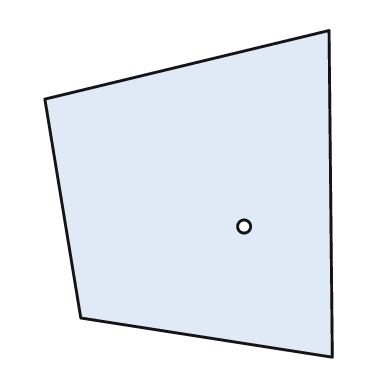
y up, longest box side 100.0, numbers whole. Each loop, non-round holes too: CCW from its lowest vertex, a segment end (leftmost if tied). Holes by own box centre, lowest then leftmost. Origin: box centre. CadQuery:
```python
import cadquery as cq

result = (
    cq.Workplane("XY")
    .moveTo(44.0, -50.0)
    .lineTo(43.0, 50.0)
    .lineTo(-44.0, 29.0)
    .lineTo(-33.0, -38.0)
    .close()
    .moveTo(17.0, -10.0)
    .circle(2.0)
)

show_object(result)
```